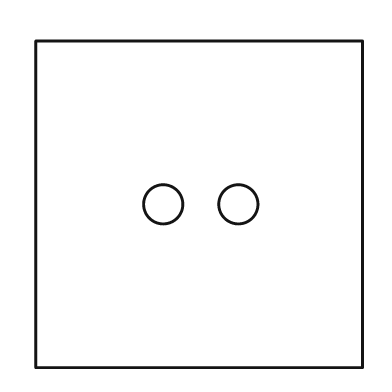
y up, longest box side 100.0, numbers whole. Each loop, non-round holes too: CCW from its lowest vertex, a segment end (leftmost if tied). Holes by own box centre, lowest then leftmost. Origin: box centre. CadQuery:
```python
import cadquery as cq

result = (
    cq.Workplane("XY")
    .moveTo(-50.0, -50.0)
    .lineTo(50.0, -50.0)
    .lineTo(50.0, 50.0)
    .lineTo(-50.0, 50.0)
    .close()
    .moveTo(-11.0, 0.0)
    .circle(6.0)
    .moveTo(12.0, 0.0)
    .circle(6.0)
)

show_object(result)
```